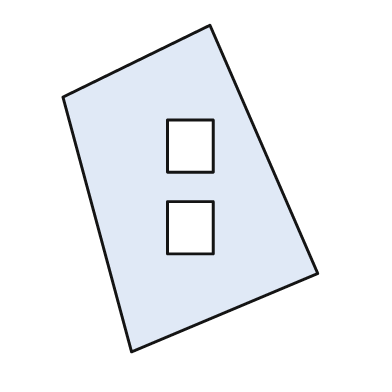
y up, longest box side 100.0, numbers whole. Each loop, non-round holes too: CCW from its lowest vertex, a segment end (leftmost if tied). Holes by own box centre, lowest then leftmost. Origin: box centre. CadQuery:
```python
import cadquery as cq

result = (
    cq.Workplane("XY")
    .moveTo(-18.0, -50.0)
    .lineTo(39.0, -26.0)
    .lineTo(6.0, 50.0)
    .lineTo(-39.0, 28.0)
    .close()
    .moveTo(-7.0, -20.0)
    .lineTo(7.0, -20.0)
    .lineTo(7.0, -4.0)
    .lineTo(-7.0, -4.0)
    .close()
    .moveTo(-7.0, 5.0)
    .lineTo(7.0, 5.0)
    .lineTo(7.0, 21.0)
    .lineTo(-7.0, 21.0)
    .close()
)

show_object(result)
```